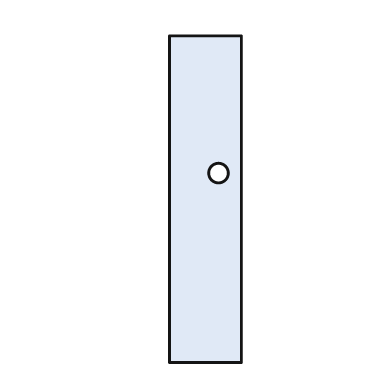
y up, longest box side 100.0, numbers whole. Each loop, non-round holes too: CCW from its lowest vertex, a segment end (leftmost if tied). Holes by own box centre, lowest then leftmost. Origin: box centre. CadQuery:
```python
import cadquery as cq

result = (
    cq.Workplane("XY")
    .moveTo(-11.0, -50.0)
    .lineTo(11.0, -50.0)
    .lineTo(11.0, 50.0)
    .lineTo(-11.0, 50.0)
    .close()
    .moveTo(4.0, 8.0)
    .circle(3.0)
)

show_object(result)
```